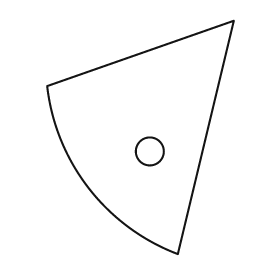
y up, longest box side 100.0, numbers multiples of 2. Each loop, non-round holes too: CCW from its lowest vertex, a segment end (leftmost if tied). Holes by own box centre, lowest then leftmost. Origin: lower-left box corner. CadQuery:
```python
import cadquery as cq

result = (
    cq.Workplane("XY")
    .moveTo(56.0, 0.0)
    .lineTo(80.0, 100.0)
    .lineTo(0.0, 72.0)
    .threePointArc((18.0, 28.0), (56.0, 0.0))
    .close()
    .moveTo(44.0, 44.0)
    .circle(6.0)
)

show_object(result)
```